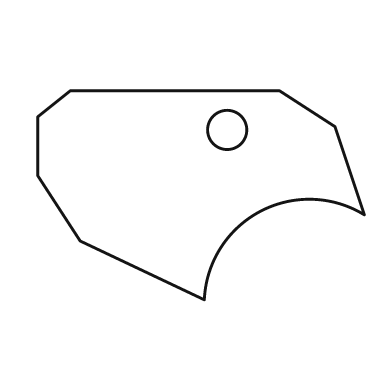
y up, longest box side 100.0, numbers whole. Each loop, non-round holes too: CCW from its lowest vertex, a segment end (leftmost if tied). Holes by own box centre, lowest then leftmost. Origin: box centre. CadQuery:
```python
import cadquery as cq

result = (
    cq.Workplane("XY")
    .moveTo(1.0, -32.0)
    .threePointArc((18.0, -5.0), (50.0, -6.0))
    .lineTo(41.0, 21.0)
    .lineTo(24.0, 32.0)
    .lineTo(-40.0, 32.0)
    .lineTo(-50.0, 24.0)
    .lineTo(-50.0, 6.0)
    .lineTo(-37.0, -14.0)
    .close()
    .moveTo(8.0, 20.0)
    .circle(6.0)
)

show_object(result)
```